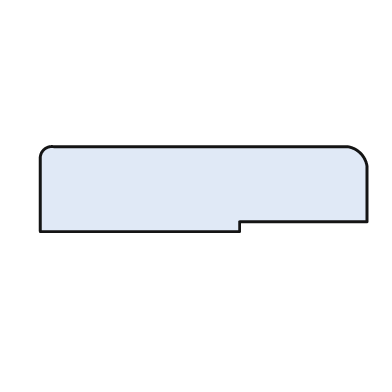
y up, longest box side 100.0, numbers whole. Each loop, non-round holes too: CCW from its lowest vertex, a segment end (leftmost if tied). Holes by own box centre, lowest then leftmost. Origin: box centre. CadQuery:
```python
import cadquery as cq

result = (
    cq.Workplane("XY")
    .moveTo(-50.0, -13.0)
    .lineTo(11.0, -13.0)
    .lineTo(11.0, -10.0)
    .lineTo(50.0, -10.0)
    .lineTo(50.0, 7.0)
    .threePointArc((48.0, 11.0), (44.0, 13.0))
    .lineTo(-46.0, 13.0)
    .threePointArc((-49.0, 12.0), (-50.0, 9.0))
    .close()
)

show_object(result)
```